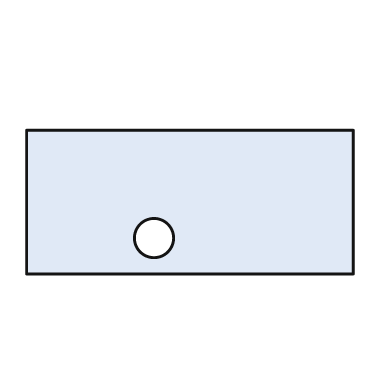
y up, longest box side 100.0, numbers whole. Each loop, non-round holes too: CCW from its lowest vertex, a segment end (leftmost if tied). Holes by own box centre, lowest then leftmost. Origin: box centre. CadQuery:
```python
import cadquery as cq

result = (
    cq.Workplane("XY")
    .moveTo(-50.0, -22.0)
    .lineTo(50.0, -22.0)
    .lineTo(50.0, 22.0)
    .lineTo(-50.0, 22.0)
    .close()
    .moveTo(-11.0, -11.0)
    .circle(6.0)
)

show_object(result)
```